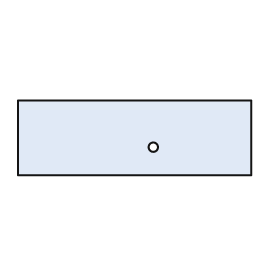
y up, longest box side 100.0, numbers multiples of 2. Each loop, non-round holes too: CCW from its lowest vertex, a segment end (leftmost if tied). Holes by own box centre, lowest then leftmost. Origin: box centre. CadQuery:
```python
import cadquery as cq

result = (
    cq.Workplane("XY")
    .moveTo(-50.0, -16.0)
    .lineTo(50.0, -16.0)
    .lineTo(50.0, 16.0)
    .lineTo(-50.0, 16.0)
    .close()
    .moveTo(8.0, -4.0)
    .circle(2.0)
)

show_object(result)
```